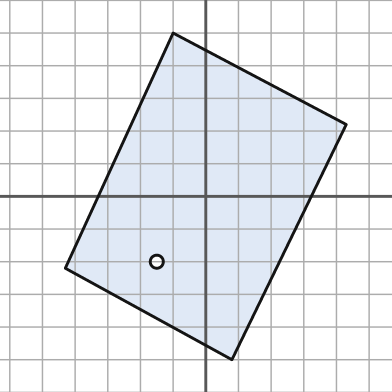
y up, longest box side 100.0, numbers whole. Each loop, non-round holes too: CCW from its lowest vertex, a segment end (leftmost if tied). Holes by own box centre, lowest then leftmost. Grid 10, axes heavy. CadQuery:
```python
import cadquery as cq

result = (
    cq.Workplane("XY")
    .moveTo(8.0, -50.0)
    .lineTo(43.0, 22.0)
    .lineTo(-10.0, 50.0)
    .lineTo(-43.0, -22.0)
    .close()
    .moveTo(-15.0, -20.0)
    .circle(2.0)
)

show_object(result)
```